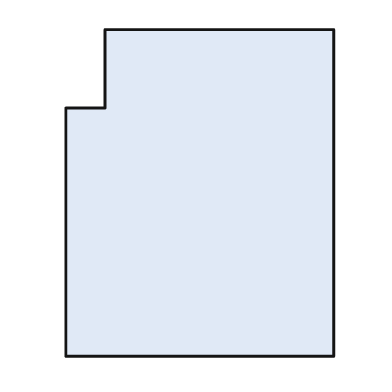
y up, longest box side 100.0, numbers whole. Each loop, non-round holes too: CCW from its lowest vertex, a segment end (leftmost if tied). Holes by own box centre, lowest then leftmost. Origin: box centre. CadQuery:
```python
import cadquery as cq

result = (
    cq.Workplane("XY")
    .moveTo(-41.0, -50.0)
    .lineTo(41.0, -50.0)
    .lineTo(41.0, 50.0)
    .lineTo(-29.0, 50.0)
    .lineTo(-29.0, 26.0)
    .lineTo(-41.0, 26.0)
    .close()
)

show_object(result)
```